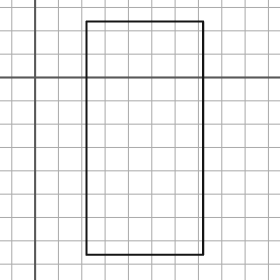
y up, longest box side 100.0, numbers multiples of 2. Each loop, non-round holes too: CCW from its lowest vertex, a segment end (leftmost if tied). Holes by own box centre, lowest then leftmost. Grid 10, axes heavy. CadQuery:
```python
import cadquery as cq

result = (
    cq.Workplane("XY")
    .moveTo(22.0, -76.0)
    .lineTo(72.0, -76.0)
    .lineTo(72.0, 24.0)
    .lineTo(22.0, 24.0)
    .close()
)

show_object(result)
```